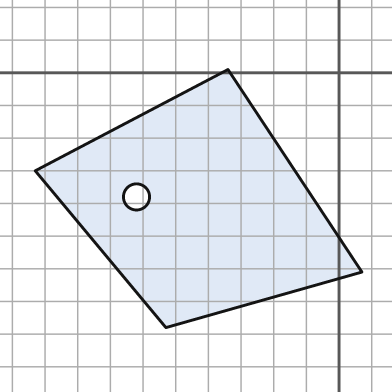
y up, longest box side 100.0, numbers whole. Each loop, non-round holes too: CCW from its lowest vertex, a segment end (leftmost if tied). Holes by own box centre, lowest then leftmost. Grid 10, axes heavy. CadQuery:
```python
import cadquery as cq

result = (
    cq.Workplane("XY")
    .moveTo(-53.0, -78.0)
    .lineTo(7.0, -61.0)
    .lineTo(-34.0, 1.0)
    .lineTo(-93.0, -30.0)
    .close()
    .moveTo(-62.0, -38.0)
    .circle(4.0)
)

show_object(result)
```